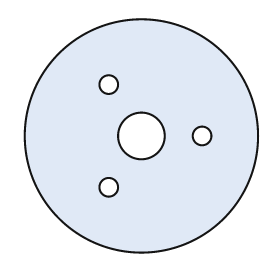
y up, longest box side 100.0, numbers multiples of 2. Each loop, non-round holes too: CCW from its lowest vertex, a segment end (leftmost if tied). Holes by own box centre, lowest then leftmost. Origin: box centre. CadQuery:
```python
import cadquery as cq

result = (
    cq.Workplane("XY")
    .moveTo(0.0, 0.0)
    .circle(50.0)
    .moveTo(-14.0, -22.0)
    .circle(4.0)
    .moveTo(0.0, 0.0)
    .circle(10.0)
    .moveTo(26.0, 0.0)
    .circle(4.0)
    .moveTo(-14.0, 22.0)
    .circle(4.0)
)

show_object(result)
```